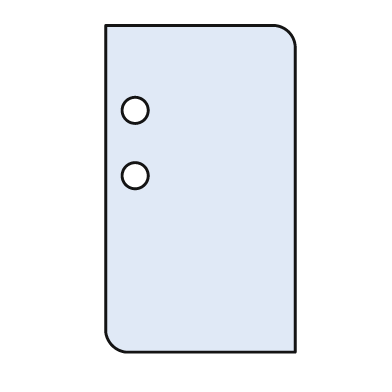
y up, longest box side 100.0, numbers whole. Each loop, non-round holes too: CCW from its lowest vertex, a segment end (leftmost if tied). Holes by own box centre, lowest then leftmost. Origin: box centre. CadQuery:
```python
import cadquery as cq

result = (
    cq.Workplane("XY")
    .moveTo(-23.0, -50.0)
    .lineTo(29.0, -50.0)
    .lineTo(29.0, 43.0)
    .threePointArc((27.0, 48.0), (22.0, 50.0))
    .lineTo(-29.0, 50.0)
    .lineTo(-29.0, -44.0)
    .threePointArc((-27.0, -48.0), (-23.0, -50.0))
    .close()
    .moveTo(-20.0, 4.0)
    .circle(4.0)
    .moveTo(-20.0, 24.0)
    .circle(4.0)
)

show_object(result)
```